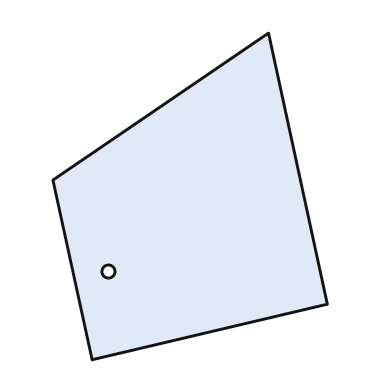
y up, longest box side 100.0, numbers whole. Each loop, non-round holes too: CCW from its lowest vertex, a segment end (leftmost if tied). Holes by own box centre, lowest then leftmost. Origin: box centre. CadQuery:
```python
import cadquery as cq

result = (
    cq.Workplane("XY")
    .moveTo(-30.0, -50.0)
    .lineTo(42.0, -33.0)
    .lineTo(24.0, 50.0)
    .lineTo(-42.0, 5.0)
    .close()
    .moveTo(-25.0, -23.0)
    .circle(2.0)
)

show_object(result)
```